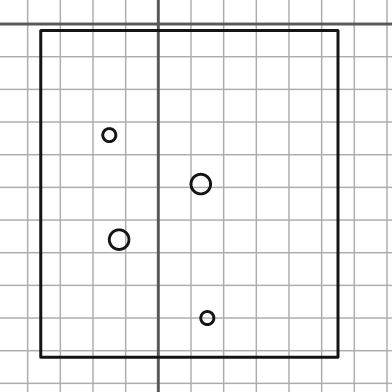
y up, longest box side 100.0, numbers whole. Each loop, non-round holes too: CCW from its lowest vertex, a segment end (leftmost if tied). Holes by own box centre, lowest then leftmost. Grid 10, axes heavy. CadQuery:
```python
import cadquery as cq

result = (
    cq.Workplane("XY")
    .moveTo(-36.0, -102.0)
    .lineTo(55.0, -102.0)
    .lineTo(55.0, -2.0)
    .lineTo(-36.0, -2.0)
    .close()
    .moveTo(15.0, -90.0)
    .circle(2.0)
    .moveTo(-12.0, -66.0)
    .circle(3.0)
    .moveTo(13.0, -49.0)
    .circle(3.0)
    .moveTo(-15.0, -34.0)
    .circle(2.0)
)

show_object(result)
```